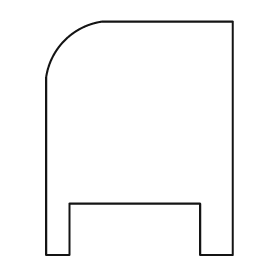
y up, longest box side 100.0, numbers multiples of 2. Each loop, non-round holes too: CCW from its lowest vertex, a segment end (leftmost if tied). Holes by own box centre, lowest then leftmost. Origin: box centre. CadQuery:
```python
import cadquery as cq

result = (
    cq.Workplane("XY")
    .moveTo(-40.0, -50.0)
    .lineTo(-30.0, -50.0)
    .lineTo(-30.0, -28.0)
    .lineTo(26.0, -28.0)
    .lineTo(26.0, -50.0)
    .lineTo(40.0, -50.0)
    .lineTo(40.0, 50.0)
    .lineTo(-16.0, 50.0)
    .threePointArc((-32.0, 42.0), (-40.0, 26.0))
    .close()
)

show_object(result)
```